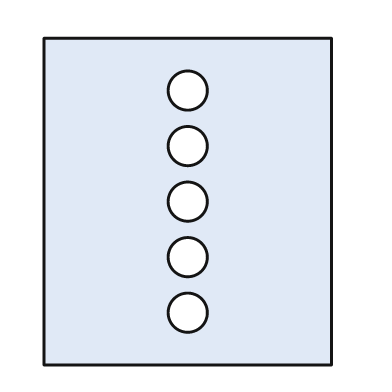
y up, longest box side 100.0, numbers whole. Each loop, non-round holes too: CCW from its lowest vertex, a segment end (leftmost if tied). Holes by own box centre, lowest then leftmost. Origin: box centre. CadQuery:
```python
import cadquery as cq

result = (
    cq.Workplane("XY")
    .moveTo(-44.0, -50.0)
    .lineTo(44.0, -50.0)
    .lineTo(44.0, 50.0)
    .lineTo(-44.0, 50.0)
    .close()
    .moveTo(0.0, -34.0)
    .circle(6.0)
    .moveTo(0.0, -17.0)
    .circle(6.0)
    .moveTo(0.0, 0.0)
    .circle(6.0)
    .moveTo(0.0, 17.0)
    .circle(6.0)
    .moveTo(0.0, 34.0)
    .circle(6.0)
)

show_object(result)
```